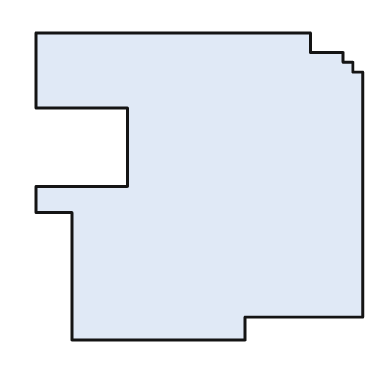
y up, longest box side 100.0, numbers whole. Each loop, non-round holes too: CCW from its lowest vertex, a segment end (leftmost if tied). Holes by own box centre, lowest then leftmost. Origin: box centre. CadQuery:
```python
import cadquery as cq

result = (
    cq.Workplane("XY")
    .moveTo(-39.0, -47.0)
    .lineTo(14.0, -47.0)
    .lineTo(14.0, -40.0)
    .lineTo(50.0, -40.0)
    .lineTo(50.0, 35.0)
    .lineTo(47.0, 35.0)
    .lineTo(47.0, 38.0)
    .lineTo(44.0, 38.0)
    .lineTo(44.0, 41.0)
    .lineTo(34.0, 41.0)
    .lineTo(34.0, 47.0)
    .lineTo(-50.0, 47.0)
    .lineTo(-50.0, 24.0)
    .lineTo(-22.0, 24.0)
    .lineTo(-22.0, 0.0)
    .lineTo(-50.0, 0.0)
    .lineTo(-50.0, -8.0)
    .lineTo(-39.0, -8.0)
    .close()
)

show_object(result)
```